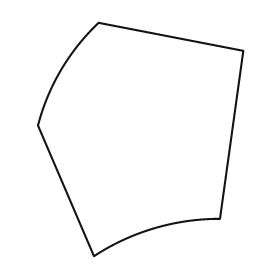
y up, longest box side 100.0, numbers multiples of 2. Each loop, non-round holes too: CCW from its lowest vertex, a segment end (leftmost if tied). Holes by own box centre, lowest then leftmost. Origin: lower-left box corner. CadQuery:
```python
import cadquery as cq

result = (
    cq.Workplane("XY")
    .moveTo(24.0, 0.0)
    .threePointArc((50.0, 12.0), (78.0, 16.0))
    .lineTo(88.0, 88.0)
    .lineTo(26.0, 100.0)
    .threePointArc((10.0, 80.0), (0.0, 56.0))
    .close()
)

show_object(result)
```